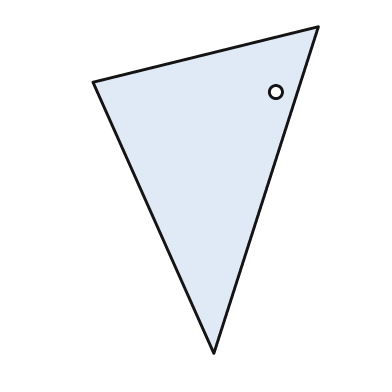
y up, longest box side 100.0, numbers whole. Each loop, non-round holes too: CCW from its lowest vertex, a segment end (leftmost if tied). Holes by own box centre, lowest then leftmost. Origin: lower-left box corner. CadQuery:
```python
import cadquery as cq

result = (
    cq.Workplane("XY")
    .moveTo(37.0, 0.0)
    .lineTo(69.0, 100.0)
    .lineTo(0.0, 83.0)
    .close()
    .moveTo(56.0, 80.0)
    .circle(2.0)
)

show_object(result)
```